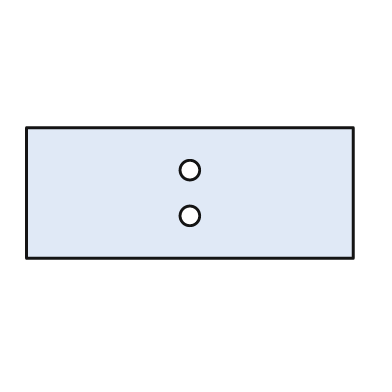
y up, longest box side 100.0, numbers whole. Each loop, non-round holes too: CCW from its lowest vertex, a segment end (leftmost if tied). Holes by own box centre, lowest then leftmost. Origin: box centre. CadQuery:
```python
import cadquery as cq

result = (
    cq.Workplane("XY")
    .moveTo(-50.0, -20.0)
    .lineTo(50.0, -20.0)
    .lineTo(50.0, 20.0)
    .lineTo(-50.0, 20.0)
    .close()
    .moveTo(0.0, -7.0)
    .circle(3.0)
    .moveTo(0.0, 7.0)
    .circle(3.0)
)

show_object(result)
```